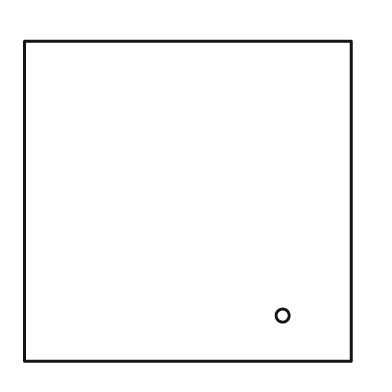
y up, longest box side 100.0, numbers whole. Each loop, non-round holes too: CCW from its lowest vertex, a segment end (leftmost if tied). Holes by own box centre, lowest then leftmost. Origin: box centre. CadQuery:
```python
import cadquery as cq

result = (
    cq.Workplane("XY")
    .moveTo(-50.0, -49.0)
    .lineTo(50.0, -49.0)
    .lineTo(50.0, 49.0)
    .lineTo(-50.0, 49.0)
    .close()
    .moveTo(29.0, -35.0)
    .circle(2.0)
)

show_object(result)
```